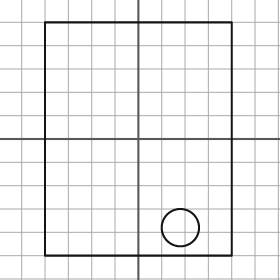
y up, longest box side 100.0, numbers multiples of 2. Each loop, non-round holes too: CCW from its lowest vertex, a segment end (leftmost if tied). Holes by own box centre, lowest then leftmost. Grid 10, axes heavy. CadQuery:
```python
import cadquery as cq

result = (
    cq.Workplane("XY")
    .moveTo(-40.0, -50.0)
    .lineTo(40.0, -50.0)
    .lineTo(40.0, 50.0)
    .lineTo(-40.0, 50.0)
    .close()
    .moveTo(18.0, -38.0)
    .circle(8.0)
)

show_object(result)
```